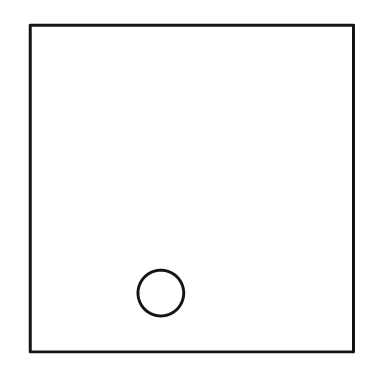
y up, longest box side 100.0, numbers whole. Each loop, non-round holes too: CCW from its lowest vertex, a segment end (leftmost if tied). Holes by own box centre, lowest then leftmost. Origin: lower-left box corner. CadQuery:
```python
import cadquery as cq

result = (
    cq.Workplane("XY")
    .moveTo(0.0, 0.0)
    .lineTo(99.0, 0.0)
    .lineTo(99.0, 100.0)
    .lineTo(0.0, 100.0)
    .close()
    .moveTo(40.0, 18.0)
    .circle(7.0)
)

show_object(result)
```